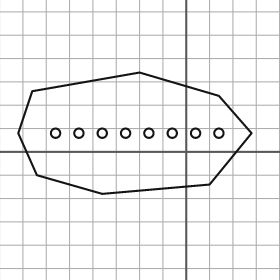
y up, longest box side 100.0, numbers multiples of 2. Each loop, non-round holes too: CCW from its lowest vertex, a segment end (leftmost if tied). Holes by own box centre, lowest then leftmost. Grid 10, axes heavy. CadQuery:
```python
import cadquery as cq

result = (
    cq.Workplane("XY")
    .moveTo(-36.0, -18.0)
    .lineTo(10.0, -14.0)
    .lineTo(28.0, 8.0)
    .lineTo(14.0, 24.0)
    .lineTo(-20.0, 34.0)
    .lineTo(-66.0, 26.0)
    .lineTo(-72.0, 8.0)
    .lineTo(-64.0, -10.0)
    .close()
    .moveTo(-56.0, 8.0)
    .circle(2.0)
    .moveTo(-46.0, 8.0)
    .circle(2.0)
    .moveTo(-36.0, 8.0)
    .circle(2.0)
    .moveTo(-26.0, 8.0)
    .circle(2.0)
    .moveTo(-16.0, 8.0)
    .circle(2.0)
    .moveTo(-6.0, 8.0)
    .circle(2.0)
    .moveTo(4.0, 8.0)
    .circle(2.0)
    .moveTo(14.0, 8.0)
    .circle(2.0)
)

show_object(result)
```